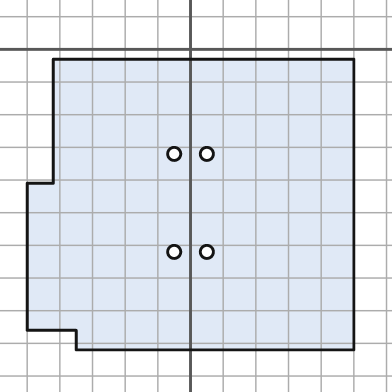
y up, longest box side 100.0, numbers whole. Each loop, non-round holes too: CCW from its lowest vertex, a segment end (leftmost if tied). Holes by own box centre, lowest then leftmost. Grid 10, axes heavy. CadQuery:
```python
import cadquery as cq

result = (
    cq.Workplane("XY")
    .moveTo(-35.0, -92.0)
    .lineTo(50.0, -92.0)
    .lineTo(50.0, -3.0)
    .lineTo(-42.0, -3.0)
    .lineTo(-42.0, -41.0)
    .lineTo(-50.0, -41.0)
    .lineTo(-50.0, -86.0)
    .lineTo(-35.0, -86.0)
    .close()
    .moveTo(-5.0, -62.0)
    .circle(2.0)
    .moveTo(5.0, -62.0)
    .circle(2.0)
    .moveTo(-5.0, -32.0)
    .circle(2.0)
    .moveTo(5.0, -32.0)
    .circle(2.0)
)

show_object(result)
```